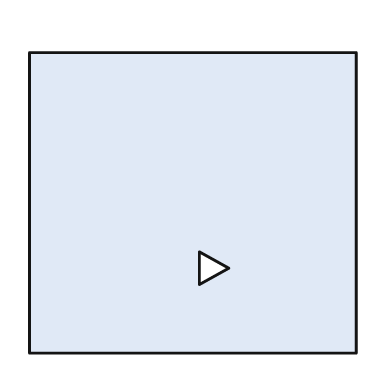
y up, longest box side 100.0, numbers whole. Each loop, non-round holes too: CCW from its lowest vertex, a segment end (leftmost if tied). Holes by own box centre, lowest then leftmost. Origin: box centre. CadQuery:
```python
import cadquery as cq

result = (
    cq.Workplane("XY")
    .moveTo(-50.0, -46.0)
    .lineTo(50.0, -46.0)
    .lineTo(50.0, 46.0)
    .lineTo(-50.0, 46.0)
    .close()
    .moveTo(2.0, -25.0)
    .lineTo(11.0, -20.0)
    .lineTo(2.0, -15.0)
    .close()
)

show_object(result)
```